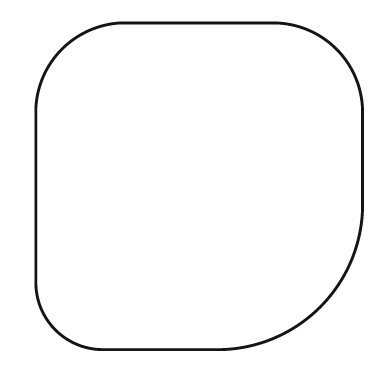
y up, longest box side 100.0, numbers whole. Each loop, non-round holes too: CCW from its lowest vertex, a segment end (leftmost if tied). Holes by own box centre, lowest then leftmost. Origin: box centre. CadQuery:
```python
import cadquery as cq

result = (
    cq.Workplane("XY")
    .moveTo(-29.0, -50.0)
    .lineTo(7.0, -50.0)
    .threePointArc((37.0, -37.0), (50.0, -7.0))
    .lineTo(50.0, 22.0)
    .threePointArc((42.0, 42.0), (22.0, 50.0))
    .lineTo(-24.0, 50.0)
    .threePointArc((-42.0, 42.0), (-50.0, 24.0))
    .lineTo(-50.0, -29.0)
    .threePointArc((-44.0, -44.0), (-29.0, -50.0))
    .close()
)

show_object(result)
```